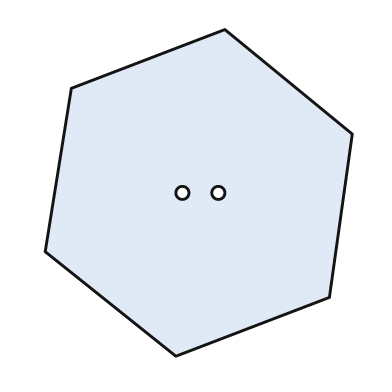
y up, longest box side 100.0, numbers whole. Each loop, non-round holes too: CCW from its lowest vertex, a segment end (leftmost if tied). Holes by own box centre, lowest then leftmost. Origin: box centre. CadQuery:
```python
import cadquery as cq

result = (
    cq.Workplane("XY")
    .moveTo(-7.0, -50.0)
    .lineTo(40.0, -32.0)
    .lineTo(47.0, 18.0)
    .lineTo(8.0, 50.0)
    .lineTo(-39.0, 32.0)
    .lineTo(-47.0, -18.0)
    .close()
    .moveTo(-5.0, 0.0)
    .circle(2.0)
    .moveTo(6.0, 0.0)
    .circle(2.0)
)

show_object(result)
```